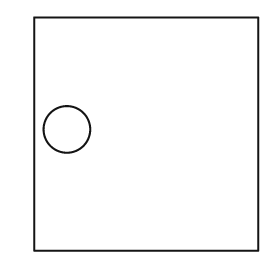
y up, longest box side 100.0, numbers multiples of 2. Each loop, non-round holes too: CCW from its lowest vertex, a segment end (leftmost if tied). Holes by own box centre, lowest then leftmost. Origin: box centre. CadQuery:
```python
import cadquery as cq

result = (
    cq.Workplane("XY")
    .moveTo(-48.0, -50.0)
    .lineTo(48.0, -50.0)
    .lineTo(48.0, 50.0)
    .lineTo(-48.0, 50.0)
    .close()
    .moveTo(-34.0, 2.0)
    .circle(10.0)
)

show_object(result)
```